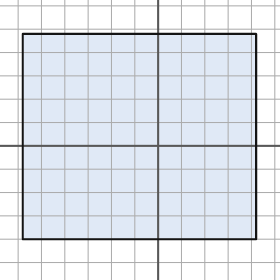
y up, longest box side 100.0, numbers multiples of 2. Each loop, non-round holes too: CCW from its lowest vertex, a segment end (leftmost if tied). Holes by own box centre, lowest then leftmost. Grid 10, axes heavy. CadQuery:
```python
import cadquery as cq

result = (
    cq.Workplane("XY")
    .moveTo(-58.0, -40.0)
    .lineTo(42.0, -40.0)
    .lineTo(42.0, 48.0)
    .lineTo(-58.0, 48.0)
    .close()
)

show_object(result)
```